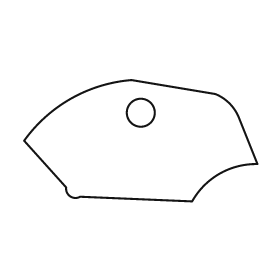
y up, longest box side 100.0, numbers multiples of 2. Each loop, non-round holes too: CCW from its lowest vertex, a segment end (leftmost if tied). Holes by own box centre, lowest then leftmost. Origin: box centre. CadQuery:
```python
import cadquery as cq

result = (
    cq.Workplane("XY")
    .moveTo(22.0, -26.0)
    .threePointArc((34.0, -14.0), (50.0, -10.0))
    .lineTo(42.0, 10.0)
    .threePointArc((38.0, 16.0), (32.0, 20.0))
    .lineTo(-4.0, 26.0)
    .threePointArc((-30.0, 18.0), (-50.0, 0.0))
    .lineTo(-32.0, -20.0)
    .threePointArc((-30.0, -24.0), (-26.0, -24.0))
    .close()
    .moveTo(0.0, 12.0)
    .circle(6.0)
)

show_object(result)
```